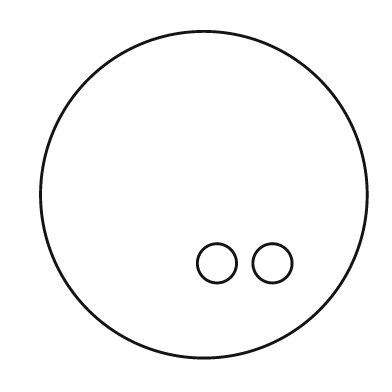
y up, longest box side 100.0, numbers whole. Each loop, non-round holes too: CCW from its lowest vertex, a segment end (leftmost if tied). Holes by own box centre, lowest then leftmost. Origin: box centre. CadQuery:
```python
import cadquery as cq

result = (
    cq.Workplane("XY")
    .moveTo(0.0, 0.0)
    .circle(50.0)
    .moveTo(4.0, -21.0)
    .circle(6.0)
    .moveTo(21.0, -21.0)
    .circle(6.0)
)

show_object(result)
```